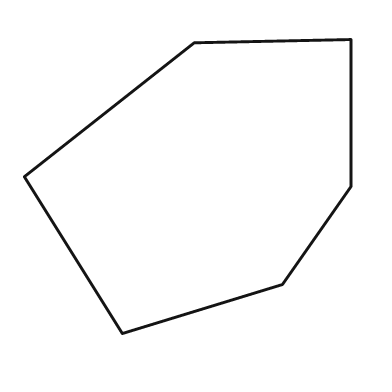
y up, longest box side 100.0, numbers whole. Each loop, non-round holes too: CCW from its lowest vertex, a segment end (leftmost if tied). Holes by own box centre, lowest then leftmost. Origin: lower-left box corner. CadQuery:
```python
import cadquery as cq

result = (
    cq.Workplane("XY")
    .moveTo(30.0, 0.0)
    .lineTo(79.0, 15.0)
    .lineTo(100.0, 45.0)
    .lineTo(100.0, 90.0)
    .lineTo(52.0, 89.0)
    .lineTo(0.0, 48.0)
    .close()
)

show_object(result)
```